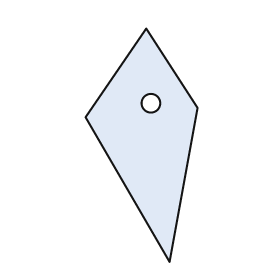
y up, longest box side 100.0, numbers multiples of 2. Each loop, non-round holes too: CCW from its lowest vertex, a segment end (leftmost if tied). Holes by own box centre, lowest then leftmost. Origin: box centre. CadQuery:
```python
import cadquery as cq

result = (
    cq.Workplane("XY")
    .moveTo(12.0, -50.0)
    .lineTo(24.0, 16.0)
    .lineTo(2.0, 50.0)
    .lineTo(-24.0, 12.0)
    .close()
    .moveTo(4.0, 18.0)
    .circle(4.0)
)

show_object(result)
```